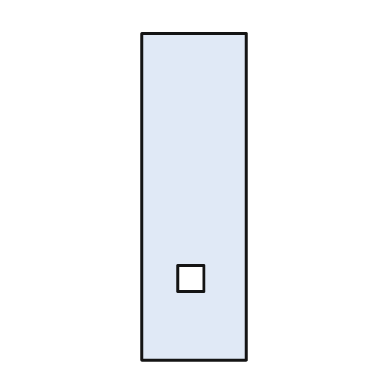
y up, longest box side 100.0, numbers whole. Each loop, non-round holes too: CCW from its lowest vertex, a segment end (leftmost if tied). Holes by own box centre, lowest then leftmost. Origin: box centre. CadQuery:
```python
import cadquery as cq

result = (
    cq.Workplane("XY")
    .moveTo(-16.0, -50.0)
    .lineTo(16.0, -50.0)
    .lineTo(16.0, 50.0)
    .lineTo(-16.0, 50.0)
    .close()
    .moveTo(-5.0, -29.0)
    .lineTo(3.0, -29.0)
    .lineTo(3.0, -21.0)
    .lineTo(-5.0, -21.0)
    .close()
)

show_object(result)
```